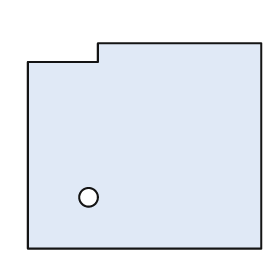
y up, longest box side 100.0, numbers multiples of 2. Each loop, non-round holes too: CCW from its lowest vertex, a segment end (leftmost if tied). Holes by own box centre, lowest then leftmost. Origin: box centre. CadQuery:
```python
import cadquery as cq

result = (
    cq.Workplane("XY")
    .moveTo(-50.0, -44.0)
    .lineTo(50.0, -44.0)
    .lineTo(50.0, 44.0)
    .lineTo(-20.0, 44.0)
    .lineTo(-20.0, 36.0)
    .lineTo(-50.0, 36.0)
    .close()
    .moveTo(-24.0, -22.0)
    .circle(4.0)
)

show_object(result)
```